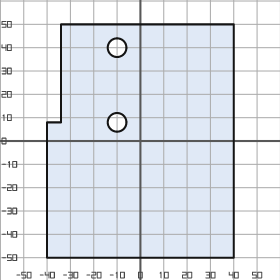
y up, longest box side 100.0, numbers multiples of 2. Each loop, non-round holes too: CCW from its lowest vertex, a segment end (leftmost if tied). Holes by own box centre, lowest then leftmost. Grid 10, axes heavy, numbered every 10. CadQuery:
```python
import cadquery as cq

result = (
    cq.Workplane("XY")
    .moveTo(-40.0, -50.0)
    .lineTo(40.0, -50.0)
    .lineTo(40.0, 50.0)
    .lineTo(-34.0, 50.0)
    .lineTo(-34.0, 8.0)
    .lineTo(-40.0, 8.0)
    .close()
    .moveTo(-10.0, 8.0)
    .circle(4.0)
    .moveTo(-10.0, 40.0)
    .circle(4.0)
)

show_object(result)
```